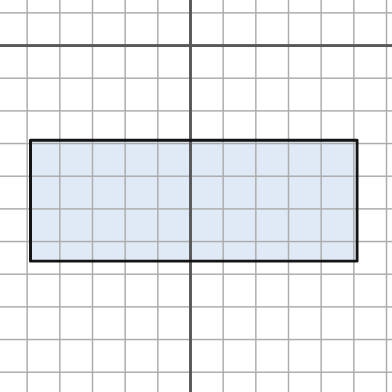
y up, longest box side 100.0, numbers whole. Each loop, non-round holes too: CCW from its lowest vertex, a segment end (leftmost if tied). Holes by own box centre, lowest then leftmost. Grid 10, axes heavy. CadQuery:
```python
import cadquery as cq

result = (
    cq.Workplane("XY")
    .moveTo(-49.0, -66.0)
    .lineTo(51.0, -66.0)
    .lineTo(51.0, -29.0)
    .lineTo(-49.0, -29.0)
    .close()
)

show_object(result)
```